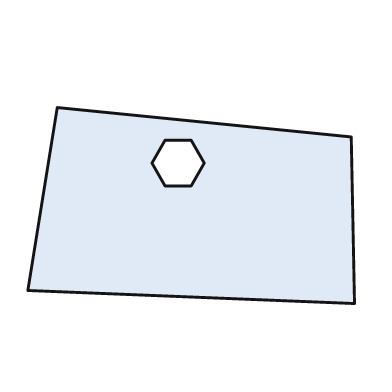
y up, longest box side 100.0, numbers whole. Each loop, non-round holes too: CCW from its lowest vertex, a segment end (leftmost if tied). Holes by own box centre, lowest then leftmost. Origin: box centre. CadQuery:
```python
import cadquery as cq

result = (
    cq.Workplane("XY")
    .moveTo(50.0, -30.0)
    .lineTo(49.0, 21.0)
    .lineTo(-41.0, 30.0)
    .lineTo(-50.0, -26.0)
    .close()
    .moveTo(-8.0, 6.0)
    .lineTo(0.0, 6.0)
    .lineTo(4.0, 13.0)
    .lineTo(0.0, 20.0)
    .lineTo(-8.0, 20.0)
    .lineTo(-12.0, 13.0)
    .close()
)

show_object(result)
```